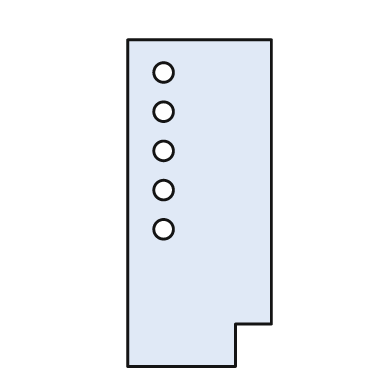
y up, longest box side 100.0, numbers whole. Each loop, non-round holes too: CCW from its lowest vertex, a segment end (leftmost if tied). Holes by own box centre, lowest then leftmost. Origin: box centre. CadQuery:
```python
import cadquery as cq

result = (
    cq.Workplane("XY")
    .moveTo(-22.0, -50.0)
    .lineTo(11.0, -50.0)
    .lineTo(11.0, -37.0)
    .lineTo(22.0, -37.0)
    .lineTo(22.0, 50.0)
    .lineTo(-22.0, 50.0)
    .close()
    .moveTo(-11.0, -8.0)
    .circle(3.0)
    .moveTo(-11.0, 4.0)
    .circle(3.0)
    .moveTo(-11.0, 16.0)
    .circle(3.0)
    .moveTo(-11.0, 28.0)
    .circle(3.0)
    .moveTo(-11.0, 40.0)
    .circle(3.0)
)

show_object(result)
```